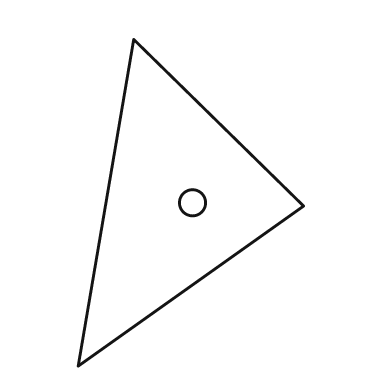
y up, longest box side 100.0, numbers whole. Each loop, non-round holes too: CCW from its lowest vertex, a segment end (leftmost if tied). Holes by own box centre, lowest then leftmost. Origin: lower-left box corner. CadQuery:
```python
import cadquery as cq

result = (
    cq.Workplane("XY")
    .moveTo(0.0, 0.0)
    .lineTo(69.0, 49.0)
    .lineTo(17.0, 100.0)
    .close()
    .moveTo(35.0, 50.0)
    .circle(4.0)
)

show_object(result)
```